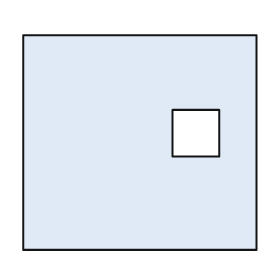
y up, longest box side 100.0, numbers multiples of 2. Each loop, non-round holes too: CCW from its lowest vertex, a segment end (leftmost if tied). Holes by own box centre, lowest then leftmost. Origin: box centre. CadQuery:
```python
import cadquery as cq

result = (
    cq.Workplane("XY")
    .moveTo(-50.0, -46.0)
    .lineTo(50.0, -46.0)
    .lineTo(50.0, 46.0)
    .lineTo(-50.0, 46.0)
    .close()
    .moveTo(14.0, -6.0)
    .lineTo(34.0, -6.0)
    .lineTo(34.0, 14.0)
    .lineTo(14.0, 14.0)
    .close()
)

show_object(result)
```